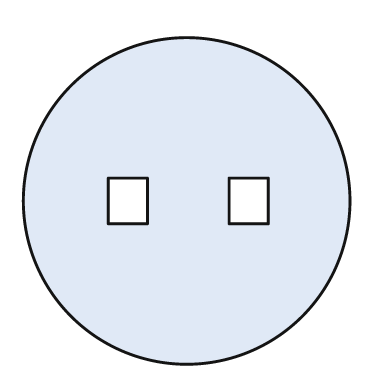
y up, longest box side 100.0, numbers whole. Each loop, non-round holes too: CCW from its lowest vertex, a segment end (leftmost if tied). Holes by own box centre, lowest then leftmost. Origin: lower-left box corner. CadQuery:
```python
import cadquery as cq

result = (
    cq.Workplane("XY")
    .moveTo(50.0, 50.0)
    .circle(50.0)
    .moveTo(26.0, 43.0)
    .lineTo(38.0, 43.0)
    .lineTo(38.0, 57.0)
    .lineTo(26.0, 57.0)
    .close()
    .moveTo(63.0, 43.0)
    .lineTo(75.0, 43.0)
    .lineTo(75.0, 57.0)
    .lineTo(63.0, 57.0)
    .close()
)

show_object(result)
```